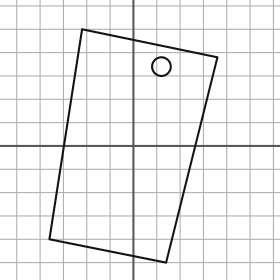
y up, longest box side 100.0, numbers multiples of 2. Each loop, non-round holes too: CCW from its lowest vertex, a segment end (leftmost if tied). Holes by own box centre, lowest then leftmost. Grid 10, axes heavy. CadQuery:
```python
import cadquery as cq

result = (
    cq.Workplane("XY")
    .moveTo(14.0, -50.0)
    .lineTo(36.0, 38.0)
    .lineTo(-22.0, 50.0)
    .lineTo(-36.0, -40.0)
    .close()
    .moveTo(12.0, 34.0)
    .circle(4.0)
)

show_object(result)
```